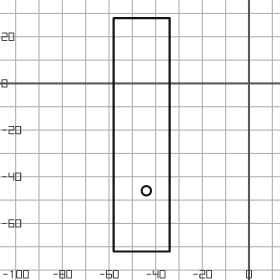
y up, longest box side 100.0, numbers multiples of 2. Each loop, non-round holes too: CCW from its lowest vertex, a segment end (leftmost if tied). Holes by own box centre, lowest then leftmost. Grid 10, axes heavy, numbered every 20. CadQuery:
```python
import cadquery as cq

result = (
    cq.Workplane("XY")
    .moveTo(-58.0, -72.0)
    .lineTo(-34.0, -72.0)
    .lineTo(-34.0, 28.0)
    .lineTo(-58.0, 28.0)
    .close()
    .moveTo(-44.0, -46.0)
    .circle(2.0)
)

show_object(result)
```